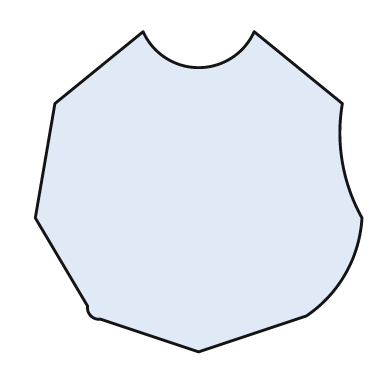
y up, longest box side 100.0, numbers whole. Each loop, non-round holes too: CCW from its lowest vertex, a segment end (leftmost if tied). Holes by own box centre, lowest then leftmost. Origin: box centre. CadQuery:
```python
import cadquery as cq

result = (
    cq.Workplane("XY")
    .moveTo(0.0, -49.0)
    .lineTo(33.0, -38.0)
    .threePointArc((45.0, -25.0), (50.0, -8.0))
    .threePointArc((44.0, 9.0), (44.0, 27.0))
    .lineTo(17.0, 49.0)
    .threePointArc((0.0, 38.0), (-17.0, 49.0))
    .lineTo(-44.0, 27.0)
    .lineTo(-50.0, -8.0)
    .lineTo(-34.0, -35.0)
    .threePointArc((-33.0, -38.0), (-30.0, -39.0))
    .close()
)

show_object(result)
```